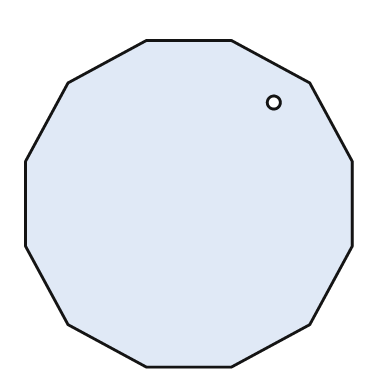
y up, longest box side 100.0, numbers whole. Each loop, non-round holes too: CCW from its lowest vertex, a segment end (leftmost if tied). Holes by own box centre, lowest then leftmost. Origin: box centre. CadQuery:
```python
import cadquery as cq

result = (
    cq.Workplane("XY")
    .moveTo(-13.0, -50.0)
    .lineTo(13.0, -50.0)
    .lineTo(37.0, -37.0)
    .lineTo(50.0, -13.0)
    .lineTo(50.0, 13.0)
    .lineTo(37.0, 37.0)
    .lineTo(13.0, 50.0)
    .lineTo(-13.0, 50.0)
    .lineTo(-37.0, 37.0)
    .lineTo(-50.0, 13.0)
    .lineTo(-50.0, -13.0)
    .lineTo(-37.0, -37.0)
    .close()
    .moveTo(26.0, 31.0)
    .circle(2.0)
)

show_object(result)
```